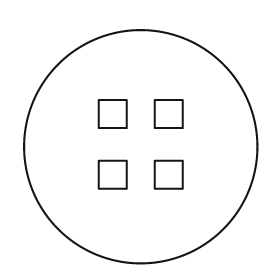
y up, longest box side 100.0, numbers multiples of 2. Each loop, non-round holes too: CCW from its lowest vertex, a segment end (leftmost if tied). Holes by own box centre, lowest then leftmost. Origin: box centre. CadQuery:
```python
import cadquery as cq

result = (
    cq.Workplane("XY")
    .moveTo(0.0, 0.0)
    .circle(50.0)
    .moveTo(-18.0, -18.0)
    .lineTo(-6.0, -18.0)
    .lineTo(-6.0, -6.0)
    .lineTo(-18.0, -6.0)
    .close()
    .moveTo(6.0, -18.0)
    .lineTo(18.0, -18.0)
    .lineTo(18.0, -6.0)
    .lineTo(6.0, -6.0)
    .close()
    .moveTo(-18.0, 8.0)
    .lineTo(-6.0, 8.0)
    .lineTo(-6.0, 20.0)
    .lineTo(-18.0, 20.0)
    .close()
    .moveTo(6.0, 8.0)
    .lineTo(18.0, 8.0)
    .lineTo(18.0, 20.0)
    .lineTo(6.0, 20.0)
    .close()
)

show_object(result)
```